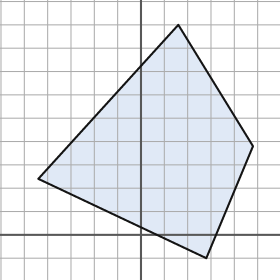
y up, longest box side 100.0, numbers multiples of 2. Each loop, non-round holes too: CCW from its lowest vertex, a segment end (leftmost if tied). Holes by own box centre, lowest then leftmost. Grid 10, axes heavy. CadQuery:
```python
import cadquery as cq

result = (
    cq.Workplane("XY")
    .moveTo(28.0, -10.0)
    .lineTo(48.0, 38.0)
    .lineTo(16.0, 90.0)
    .lineTo(-44.0, 24.0)
    .close()
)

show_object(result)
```